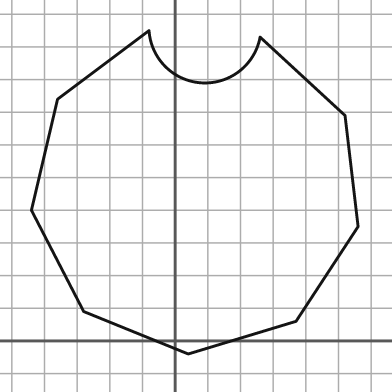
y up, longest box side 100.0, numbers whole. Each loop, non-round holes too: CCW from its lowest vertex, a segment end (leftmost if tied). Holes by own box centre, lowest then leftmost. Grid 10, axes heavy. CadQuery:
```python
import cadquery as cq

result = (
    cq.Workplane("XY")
    .moveTo(4.0, -4.0)
    .lineTo(37.0, 6.0)
    .lineTo(56.0, 35.0)
    .lineTo(52.0, 69.0)
    .lineTo(26.0, 93.0)
    .threePointArc((8.0, 79.0), (-8.0, 95.0))
    .lineTo(-36.0, 74.0)
    .lineTo(-44.0, 40.0)
    .lineTo(-28.0, 9.0)
    .close()
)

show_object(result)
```